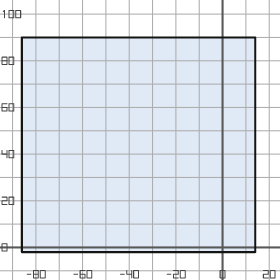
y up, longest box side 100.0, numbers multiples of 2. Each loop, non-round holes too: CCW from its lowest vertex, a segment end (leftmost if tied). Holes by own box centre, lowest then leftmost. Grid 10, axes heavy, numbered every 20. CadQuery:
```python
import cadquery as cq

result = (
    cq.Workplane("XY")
    .moveTo(-86.0, -2.0)
    .lineTo(14.0, -2.0)
    .lineTo(14.0, 90.0)
    .lineTo(-86.0, 90.0)
    .close()
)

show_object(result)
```